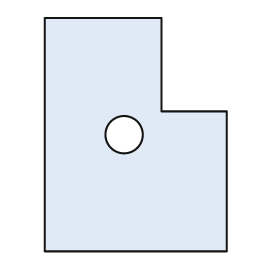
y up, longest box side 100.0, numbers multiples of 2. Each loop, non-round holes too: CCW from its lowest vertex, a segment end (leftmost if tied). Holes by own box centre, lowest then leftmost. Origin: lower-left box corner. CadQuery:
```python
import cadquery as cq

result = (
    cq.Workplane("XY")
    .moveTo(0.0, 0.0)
    .lineTo(78.0, 0.0)
    .lineTo(78.0, 60.0)
    .lineTo(50.0, 60.0)
    .lineTo(50.0, 100.0)
    .lineTo(0.0, 100.0)
    .close()
    .moveTo(34.0, 50.0)
    .circle(8.0)
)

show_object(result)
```